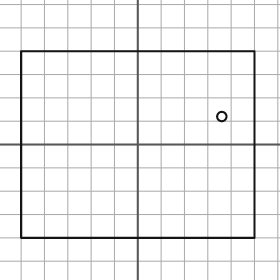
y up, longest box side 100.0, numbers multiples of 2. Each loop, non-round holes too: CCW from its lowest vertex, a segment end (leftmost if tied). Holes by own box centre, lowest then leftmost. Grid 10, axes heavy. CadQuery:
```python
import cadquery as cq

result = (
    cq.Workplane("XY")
    .moveTo(-50.0, -40.0)
    .lineTo(50.0, -40.0)
    .lineTo(50.0, 40.0)
    .lineTo(-50.0, 40.0)
    .close()
    .moveTo(36.0, 12.0)
    .circle(2.0)
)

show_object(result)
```